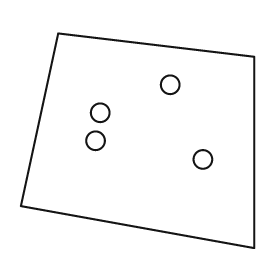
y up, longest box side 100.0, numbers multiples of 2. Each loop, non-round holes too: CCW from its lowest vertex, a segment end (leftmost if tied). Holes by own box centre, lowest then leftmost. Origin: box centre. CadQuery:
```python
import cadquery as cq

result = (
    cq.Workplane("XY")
    .moveTo(50.0, -46.0)
    .lineTo(50.0, 36.0)
    .lineTo(-34.0, 46.0)
    .lineTo(-50.0, -28.0)
    .close()
    .moveTo(28.0, -8.0)
    .circle(4.0)
    .moveTo(-18.0, 0.0)
    .circle(4.0)
    .moveTo(-16.0, 12.0)
    .circle(4.0)
    .moveTo(14.0, 24.0)
    .circle(4.0)
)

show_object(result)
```